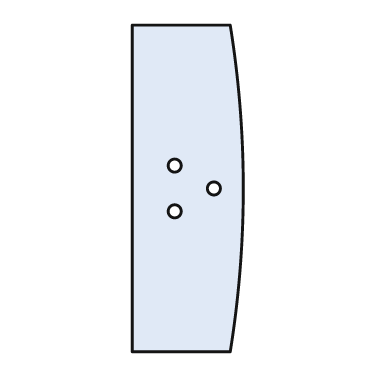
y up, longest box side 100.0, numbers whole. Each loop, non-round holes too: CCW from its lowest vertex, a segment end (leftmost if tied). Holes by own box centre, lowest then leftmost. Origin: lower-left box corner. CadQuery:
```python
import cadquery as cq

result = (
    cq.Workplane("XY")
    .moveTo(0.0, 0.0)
    .lineTo(30.0, 0.0)
    .threePointArc((34.0, 50.0), (30.0, 100.0))
    .lineTo(0.0, 100.0)
    .close()
    .moveTo(13.0, 43.0)
    .circle(2.0)
    .moveTo(25.0, 50.0)
    .circle(2.0)
    .moveTo(13.0, 57.0)
    .circle(2.0)
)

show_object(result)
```